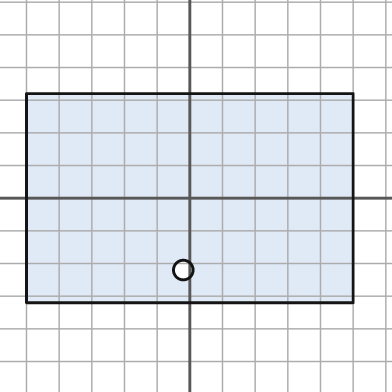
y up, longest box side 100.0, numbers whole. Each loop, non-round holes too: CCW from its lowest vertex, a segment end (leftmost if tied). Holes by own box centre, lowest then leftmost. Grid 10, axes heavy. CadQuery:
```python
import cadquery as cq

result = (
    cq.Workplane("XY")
    .moveTo(-50.0, -32.0)
    .lineTo(50.0, -32.0)
    .lineTo(50.0, 32.0)
    .lineTo(-50.0, 32.0)
    .close()
    .moveTo(-2.0, -22.0)
    .circle(3.0)
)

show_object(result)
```